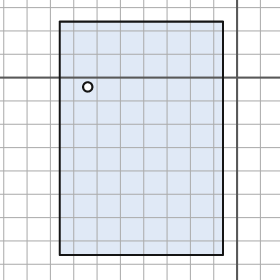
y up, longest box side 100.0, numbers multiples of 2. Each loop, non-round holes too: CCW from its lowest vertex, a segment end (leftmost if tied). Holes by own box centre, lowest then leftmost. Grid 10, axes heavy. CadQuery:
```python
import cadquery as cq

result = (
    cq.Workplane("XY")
    .moveTo(-76.0, -76.0)
    .lineTo(-6.0, -76.0)
    .lineTo(-6.0, 24.0)
    .lineTo(-76.0, 24.0)
    .close()
    .moveTo(-64.0, -4.0)
    .circle(2.0)
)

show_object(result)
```